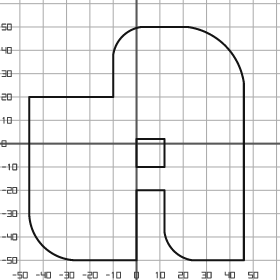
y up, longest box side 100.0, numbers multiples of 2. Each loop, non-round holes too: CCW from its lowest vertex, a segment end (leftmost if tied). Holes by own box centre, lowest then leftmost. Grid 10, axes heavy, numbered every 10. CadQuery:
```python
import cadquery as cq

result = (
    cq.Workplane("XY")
    .moveTo(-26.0, -50.0)
    .lineTo(0.0, -50.0)
    .lineTo(0.0, -20.0)
    .lineTo(12.0, -20.0)
    .lineTo(12.0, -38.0)
    .threePointArc((16.0, -46.0), (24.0, -50.0))
    .lineTo(46.0, -50.0)
    .lineTo(46.0, 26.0)
    .threePointArc((38.0, 42.0), (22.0, 50.0))
    .lineTo(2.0, 50.0)
    .threePointArc((-6.0, 46.0), (-10.0, 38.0))
    .lineTo(-10.0, 20.0)
    .lineTo(-46.0, 20.0)
    .lineTo(-46.0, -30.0)
    .threePointArc((-40.0, -44.0), (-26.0, -50.0))
    .close()
    .moveTo(0.0, -10.0)
    .lineTo(12.0, -10.0)
    .lineTo(12.0, 2.0)
    .lineTo(0.0, 2.0)
    .close()
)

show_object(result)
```